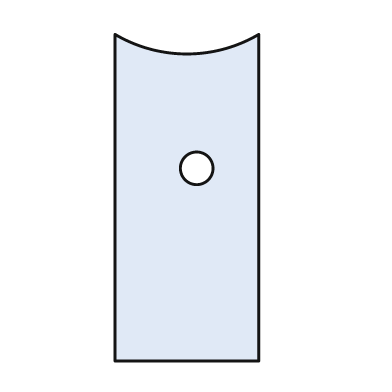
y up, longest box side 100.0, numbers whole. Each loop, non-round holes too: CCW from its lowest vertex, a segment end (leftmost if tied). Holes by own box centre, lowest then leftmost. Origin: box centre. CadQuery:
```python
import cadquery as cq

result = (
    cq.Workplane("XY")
    .moveTo(-22.0, -50.0)
    .lineTo(22.0, -50.0)
    .lineTo(22.0, 50.0)
    .threePointArc((0.0, 44.0), (-22.0, 50.0))
    .close()
    .moveTo(3.0, 9.0)
    .circle(5.0)
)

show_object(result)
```